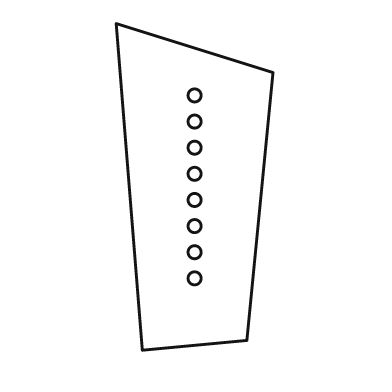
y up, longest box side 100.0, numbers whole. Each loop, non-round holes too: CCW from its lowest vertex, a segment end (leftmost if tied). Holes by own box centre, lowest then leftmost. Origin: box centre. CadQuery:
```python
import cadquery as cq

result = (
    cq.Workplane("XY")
    .moveTo(-16.0, -50.0)
    .lineTo(16.0, -47.0)
    .lineTo(24.0, 35.0)
    .lineTo(-24.0, 50.0)
    .close()
    .moveTo(0.0, -28.0)
    .circle(2.0)
    .moveTo(0.0, -20.0)
    .circle(2.0)
    .moveTo(0.0, -12.0)
    .circle(2.0)
    .moveTo(0.0, -4.0)
    .circle(2.0)
    .moveTo(0.0, 4.0)
    .circle(2.0)
    .moveTo(0.0, 12.0)
    .circle(2.0)
    .moveTo(0.0, 20.0)
    .circle(2.0)
    .moveTo(0.0, 28.0)
    .circle(2.0)
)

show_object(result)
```